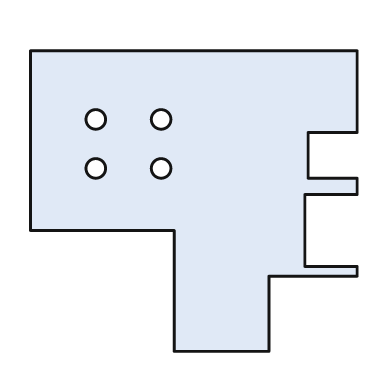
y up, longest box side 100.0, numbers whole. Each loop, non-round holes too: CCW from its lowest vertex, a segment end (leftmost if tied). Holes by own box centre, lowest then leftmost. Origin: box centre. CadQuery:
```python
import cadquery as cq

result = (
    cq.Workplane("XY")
    .moveTo(-6.0, -46.0)
    .lineTo(23.0, -46.0)
    .lineTo(23.0, -23.0)
    .lineTo(50.0, -23.0)
    .lineTo(50.0, -20.0)
    .lineTo(34.0, -20.0)
    .lineTo(34.0, 2.0)
    .lineTo(50.0, 2.0)
    .lineTo(50.0, 7.0)
    .lineTo(35.0, 7.0)
    .lineTo(35.0, 21.0)
    .lineTo(50.0, 21.0)
    .lineTo(50.0, 46.0)
    .lineTo(-50.0, 46.0)
    .lineTo(-50.0, -9.0)
    .lineTo(-6.0, -9.0)
    .close()
    .moveTo(-30.0, 10.0)
    .circle(3.0)
    .moveTo(-10.0, 10.0)
    .circle(3.0)
    .moveTo(-30.0, 25.0)
    .circle(3.0)
    .moveTo(-10.0, 25.0)
    .circle(3.0)
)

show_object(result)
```